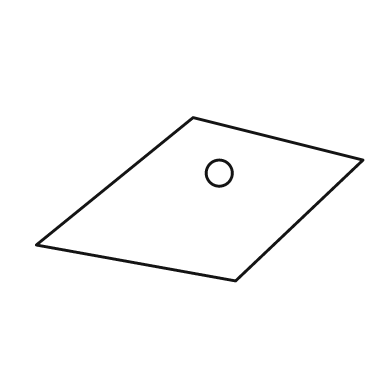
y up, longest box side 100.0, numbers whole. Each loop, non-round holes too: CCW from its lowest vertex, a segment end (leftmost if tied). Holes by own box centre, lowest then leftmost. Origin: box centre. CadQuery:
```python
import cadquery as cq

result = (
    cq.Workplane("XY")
    .moveTo(11.0, -25.0)
    .lineTo(50.0, 12.0)
    .lineTo(-2.0, 25.0)
    .lineTo(-50.0, -14.0)
    .close()
    .moveTo(6.0, 8.0)
    .circle(4.0)
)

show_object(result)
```